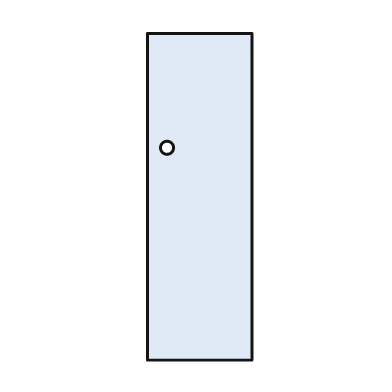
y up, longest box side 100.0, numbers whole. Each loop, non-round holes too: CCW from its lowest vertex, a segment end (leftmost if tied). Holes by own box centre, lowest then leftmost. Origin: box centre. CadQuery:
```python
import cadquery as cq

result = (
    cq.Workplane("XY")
    .moveTo(-16.0, -50.0)
    .lineTo(16.0, -50.0)
    .lineTo(16.0, 50.0)
    .lineTo(-16.0, 50.0)
    .close()
    .moveTo(-10.0, 15.0)
    .circle(2.0)
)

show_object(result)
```